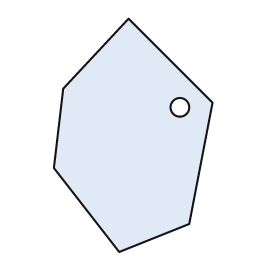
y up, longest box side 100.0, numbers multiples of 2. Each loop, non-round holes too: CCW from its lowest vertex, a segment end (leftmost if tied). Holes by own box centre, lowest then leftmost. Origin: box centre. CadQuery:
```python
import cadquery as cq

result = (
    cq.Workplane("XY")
    .moveTo(-6.0, -50.0)
    .lineTo(24.0, -38.0)
    .lineTo(34.0, 14.0)
    .lineTo(-2.0, 50.0)
    .lineTo(-30.0, 20.0)
    .lineTo(-34.0, -14.0)
    .close()
    .moveTo(20.0, 12.0)
    .circle(4.0)
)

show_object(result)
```